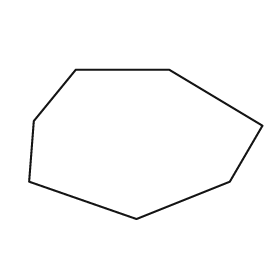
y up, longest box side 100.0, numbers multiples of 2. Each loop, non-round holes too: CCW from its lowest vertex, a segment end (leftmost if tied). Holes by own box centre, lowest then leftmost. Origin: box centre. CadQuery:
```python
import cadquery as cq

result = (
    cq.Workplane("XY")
    .moveTo(-4.0, -32.0)
    .lineTo(36.0, -16.0)
    .lineTo(50.0, 8.0)
    .lineTo(10.0, 32.0)
    .lineTo(-30.0, 32.0)
    .lineTo(-48.0, 10.0)
    .lineTo(-50.0, -16.0)
    .close()
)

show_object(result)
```